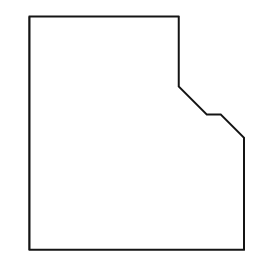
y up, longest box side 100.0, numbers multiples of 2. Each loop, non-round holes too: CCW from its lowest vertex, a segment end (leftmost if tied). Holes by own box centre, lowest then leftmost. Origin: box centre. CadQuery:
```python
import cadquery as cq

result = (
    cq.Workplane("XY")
    .moveTo(-46.0, -50.0)
    .lineTo(46.0, -50.0)
    .lineTo(46.0, -2.0)
    .lineTo(36.0, 8.0)
    .lineTo(30.0, 8.0)
    .lineTo(18.0, 20.0)
    .lineTo(18.0, 50.0)
    .lineTo(-46.0, 50.0)
    .close()
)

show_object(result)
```